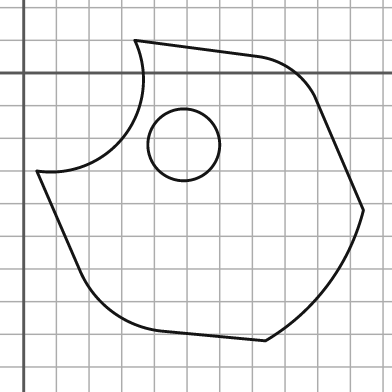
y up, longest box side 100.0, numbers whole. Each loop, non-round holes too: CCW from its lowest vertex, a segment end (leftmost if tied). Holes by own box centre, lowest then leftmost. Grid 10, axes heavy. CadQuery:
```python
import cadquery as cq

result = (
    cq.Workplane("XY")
    .moveTo(74.0, -82.0)
    .threePointArc((93.0, -65.0), (104.0, -42.0))
    .lineTo(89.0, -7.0)
    .threePointArc((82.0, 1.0), (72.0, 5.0))
    .lineTo(34.0, 10.0)
    .threePointArc((31.0, -19.0), (4.0, -30.0))
    .lineTo(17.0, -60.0)
    .threePointArc((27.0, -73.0), (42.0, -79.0))
    .close()
    .moveTo(49.0, -22.0)
    .circle(11.0)
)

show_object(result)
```